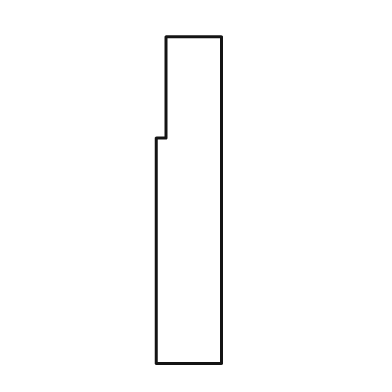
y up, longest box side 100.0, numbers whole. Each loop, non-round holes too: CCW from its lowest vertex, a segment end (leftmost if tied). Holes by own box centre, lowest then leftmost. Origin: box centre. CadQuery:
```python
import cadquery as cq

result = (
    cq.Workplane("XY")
    .moveTo(-10.0, -50.0)
    .lineTo(10.0, -50.0)
    .lineTo(10.0, 50.0)
    .lineTo(-7.0, 50.0)
    .lineTo(-7.0, 19.0)
    .lineTo(-10.0, 19.0)
    .close()
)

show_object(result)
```